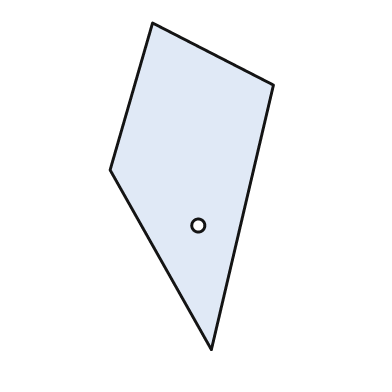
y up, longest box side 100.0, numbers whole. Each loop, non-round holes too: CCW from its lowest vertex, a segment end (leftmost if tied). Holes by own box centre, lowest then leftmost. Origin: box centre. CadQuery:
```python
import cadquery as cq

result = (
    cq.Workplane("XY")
    .moveTo(6.0, -50.0)
    .lineTo(25.0, 31.0)
    .lineTo(-12.0, 50.0)
    .lineTo(-25.0, 5.0)
    .close()
    .moveTo(2.0, -12.0)
    .circle(2.0)
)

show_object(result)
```